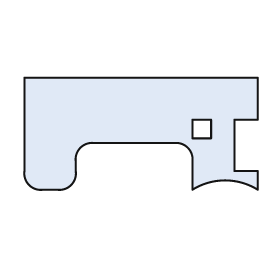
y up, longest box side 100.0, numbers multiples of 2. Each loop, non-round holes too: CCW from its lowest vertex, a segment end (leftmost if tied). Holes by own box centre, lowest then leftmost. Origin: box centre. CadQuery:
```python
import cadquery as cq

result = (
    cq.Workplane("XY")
    .moveTo(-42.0, -24.0)
    .lineTo(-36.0, -24.0)
    .threePointArc((-30.0, -22.0), (-28.0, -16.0))
    .lineTo(-28.0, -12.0)
    .threePointArc((-26.0, -6.0), (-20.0, -4.0))
    .lineTo(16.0, -4.0)
    .threePointArc((20.0, -6.0), (22.0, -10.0))
    .lineTo(22.0, -24.0)
    .threePointArc((36.0, -20.0), (50.0, -24.0))
    .lineTo(50.0, -16.0)
    .lineTo(40.0, -16.0)
    .lineTo(40.0, 6.0)
    .lineTo(50.0, 6.0)
    .lineTo(50.0, 24.0)
    .lineTo(-50.0, 24.0)
    .lineTo(-50.0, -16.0)
    .threePointArc((-48.0, -22.0), (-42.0, -24.0))
    .close()
    .moveTo(22.0, -2.0)
    .lineTo(30.0, -2.0)
    .lineTo(30.0, 6.0)
    .lineTo(22.0, 6.0)
    .close()
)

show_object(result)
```